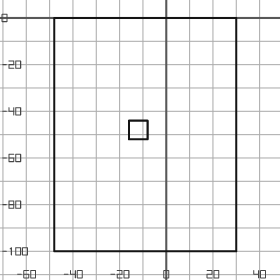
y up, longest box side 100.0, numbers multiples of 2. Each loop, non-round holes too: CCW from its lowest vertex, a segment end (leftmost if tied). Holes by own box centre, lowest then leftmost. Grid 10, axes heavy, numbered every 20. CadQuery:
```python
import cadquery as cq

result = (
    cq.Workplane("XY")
    .moveTo(-48.0, -100.0)
    .lineTo(30.0, -100.0)
    .lineTo(30.0, 0.0)
    .lineTo(-48.0, 0.0)
    .close()
    .moveTo(-16.0, -52.0)
    .lineTo(-8.0, -52.0)
    .lineTo(-8.0, -44.0)
    .lineTo(-16.0, -44.0)
    .close()
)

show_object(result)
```